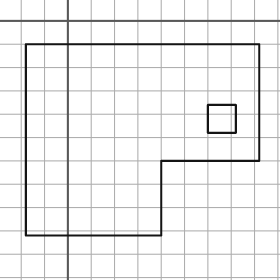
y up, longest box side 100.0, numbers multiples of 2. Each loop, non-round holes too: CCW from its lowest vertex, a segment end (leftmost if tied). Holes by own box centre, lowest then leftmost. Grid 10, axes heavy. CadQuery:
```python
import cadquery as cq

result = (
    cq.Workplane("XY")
    .moveTo(-18.0, -92.0)
    .lineTo(40.0, -92.0)
    .lineTo(40.0, -60.0)
    .lineTo(82.0, -60.0)
    .lineTo(82.0, -10.0)
    .lineTo(-18.0, -10.0)
    .close()
    .moveTo(60.0, -48.0)
    .lineTo(72.0, -48.0)
    .lineTo(72.0, -36.0)
    .lineTo(60.0, -36.0)
    .close()
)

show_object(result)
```